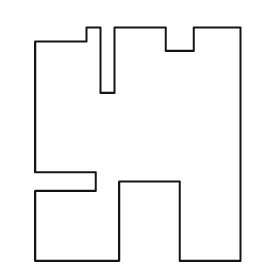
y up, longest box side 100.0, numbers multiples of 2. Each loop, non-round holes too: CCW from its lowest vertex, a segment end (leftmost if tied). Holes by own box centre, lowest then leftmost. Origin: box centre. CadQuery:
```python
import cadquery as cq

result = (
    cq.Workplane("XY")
    .moveTo(-44.0, -50.0)
    .lineTo(-8.0, -50.0)
    .lineTo(-8.0, -16.0)
    .lineTo(18.0, -16.0)
    .lineTo(18.0, -50.0)
    .lineTo(44.0, -50.0)
    .lineTo(44.0, 50.0)
    .lineTo(24.0, 50.0)
    .lineTo(24.0, 40.0)
    .lineTo(12.0, 40.0)
    .lineTo(12.0, 50.0)
    .lineTo(-10.0, 50.0)
    .lineTo(-10.0, 22.0)
    .lineTo(-16.0, 22.0)
    .lineTo(-16.0, 50.0)
    .lineTo(-22.0, 50.0)
    .lineTo(-22.0, 44.0)
    .lineTo(-44.0, 44.0)
    .lineTo(-44.0, -12.0)
    .lineTo(-18.0, -12.0)
    .lineTo(-18.0, -20.0)
    .lineTo(-44.0, -20.0)
    .close()
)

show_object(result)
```